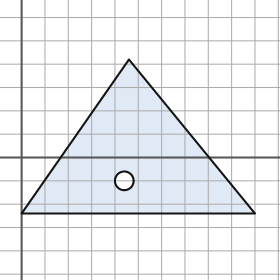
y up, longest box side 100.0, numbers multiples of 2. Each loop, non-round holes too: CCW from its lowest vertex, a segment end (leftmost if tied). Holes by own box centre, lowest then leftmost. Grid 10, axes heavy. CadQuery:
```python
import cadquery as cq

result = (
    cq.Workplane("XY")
    .moveTo(0.0, -24.0)
    .lineTo(100.0, -24.0)
    .lineTo(46.0, 42.0)
    .close()
    .moveTo(44.0, -10.0)
    .circle(4.0)
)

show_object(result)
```